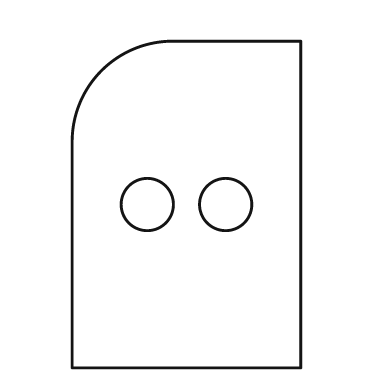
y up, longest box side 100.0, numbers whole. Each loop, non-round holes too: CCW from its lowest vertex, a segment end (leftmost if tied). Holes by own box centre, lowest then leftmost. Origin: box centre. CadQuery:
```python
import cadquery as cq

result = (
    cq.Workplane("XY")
    .moveTo(-35.0, -50.0)
    .lineTo(35.0, -50.0)
    .lineTo(35.0, 50.0)
    .lineTo(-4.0, 50.0)
    .threePointArc((-26.0, 41.0), (-35.0, 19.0))
    .close()
    .moveTo(-12.0, 0.0)
    .circle(8.0)
    .moveTo(12.0, 0.0)
    .circle(8.0)
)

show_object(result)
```